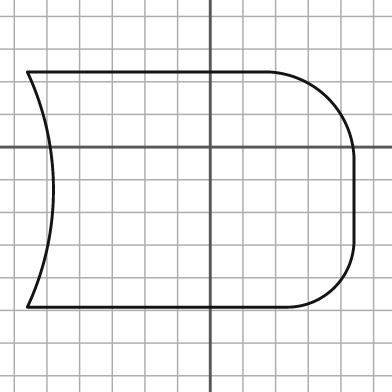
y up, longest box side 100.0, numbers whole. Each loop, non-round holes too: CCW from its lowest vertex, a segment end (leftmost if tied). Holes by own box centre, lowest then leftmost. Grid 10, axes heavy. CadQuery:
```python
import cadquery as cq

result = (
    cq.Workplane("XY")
    .moveTo(-56.0, -49.0)
    .lineTo(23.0, -49.0)
    .threePointArc((38.0, -43.0), (44.0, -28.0))
    .lineTo(44.0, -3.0)
    .threePointArc((36.0, 15.0), (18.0, 23.0))
    .lineTo(-56.0, 23.0)
    .threePointArc((-48.0, -13.0), (-56.0, -49.0))
    .close()
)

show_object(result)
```